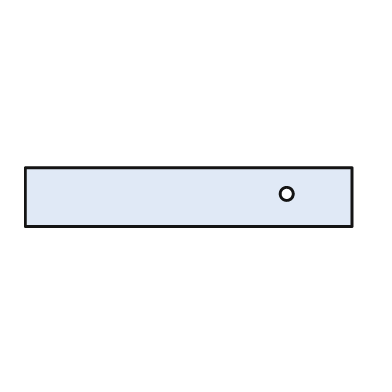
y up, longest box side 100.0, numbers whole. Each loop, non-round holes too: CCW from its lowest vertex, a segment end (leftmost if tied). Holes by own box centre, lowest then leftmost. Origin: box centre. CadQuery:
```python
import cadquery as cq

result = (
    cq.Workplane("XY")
    .moveTo(-50.0, -9.0)
    .lineTo(50.0, -9.0)
    .lineTo(50.0, 9.0)
    .lineTo(-50.0, 9.0)
    .close()
    .moveTo(30.0, 1.0)
    .circle(2.0)
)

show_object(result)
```